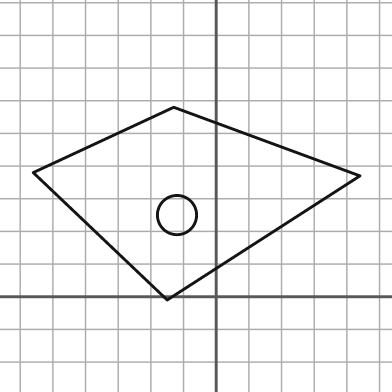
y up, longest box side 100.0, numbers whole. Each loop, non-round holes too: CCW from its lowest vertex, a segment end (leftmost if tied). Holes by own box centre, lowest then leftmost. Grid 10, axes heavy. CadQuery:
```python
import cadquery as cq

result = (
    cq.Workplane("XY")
    .moveTo(-15.0, -1.0)
    .lineTo(44.0, 37.0)
    .lineTo(-13.0, 58.0)
    .lineTo(-56.0, 38.0)
    .close()
    .moveTo(-12.0, 25.0)
    .circle(6.0)
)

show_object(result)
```